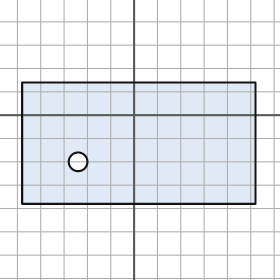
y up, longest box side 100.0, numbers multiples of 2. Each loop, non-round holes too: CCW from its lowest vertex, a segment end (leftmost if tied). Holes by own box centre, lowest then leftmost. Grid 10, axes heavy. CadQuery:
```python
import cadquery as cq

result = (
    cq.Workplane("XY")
    .moveTo(-48.0, -38.0)
    .lineTo(52.0, -38.0)
    .lineTo(52.0, 14.0)
    .lineTo(-48.0, 14.0)
    .close()
    .moveTo(-24.0, -20.0)
    .circle(4.0)
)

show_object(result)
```